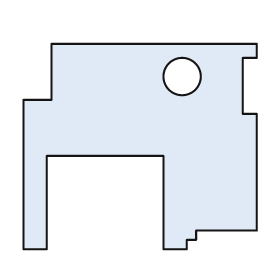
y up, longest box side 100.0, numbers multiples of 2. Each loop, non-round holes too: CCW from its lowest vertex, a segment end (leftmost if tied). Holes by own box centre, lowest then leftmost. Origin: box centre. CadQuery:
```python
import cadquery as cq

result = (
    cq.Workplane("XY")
    .moveTo(-50.0, -44.0)
    .lineTo(-40.0, -44.0)
    .lineTo(-40.0, -4.0)
    .lineTo(10.0, -4.0)
    .lineTo(10.0, -44.0)
    .lineTo(20.0, -44.0)
    .lineTo(20.0, -40.0)
    .lineTo(24.0, -40.0)
    .lineTo(24.0, -36.0)
    .lineTo(50.0, -36.0)
    .lineTo(50.0, 14.0)
    .lineTo(44.0, 14.0)
    .lineTo(44.0, 38.0)
    .lineTo(50.0, 38.0)
    .lineTo(50.0, 44.0)
    .lineTo(-38.0, 44.0)
    .lineTo(-38.0, 20.0)
    .lineTo(-50.0, 20.0)
    .close()
    .moveTo(18.0, 30.0)
    .circle(8.0)
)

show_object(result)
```